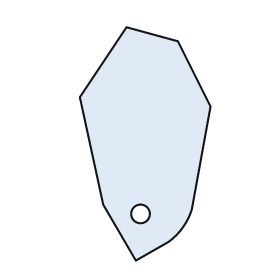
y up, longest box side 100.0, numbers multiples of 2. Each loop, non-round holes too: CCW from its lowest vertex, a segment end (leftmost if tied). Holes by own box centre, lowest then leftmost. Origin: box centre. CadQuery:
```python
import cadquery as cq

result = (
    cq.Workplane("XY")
    .moveTo(-4.0, -50.0)
    .lineTo(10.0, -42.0)
    .threePointArc((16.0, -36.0), (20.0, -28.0))
    .lineTo(28.0, 16.0)
    .lineTo(14.0, 44.0)
    .lineTo(-8.0, 50.0)
    .lineTo(-28.0, 20.0)
    .lineTo(-18.0, -26.0)
    .close()
    .moveTo(-2.0, -30.0)
    .circle(4.0)
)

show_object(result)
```